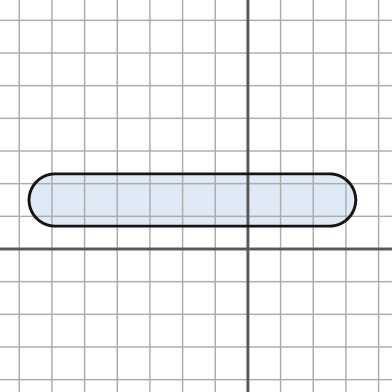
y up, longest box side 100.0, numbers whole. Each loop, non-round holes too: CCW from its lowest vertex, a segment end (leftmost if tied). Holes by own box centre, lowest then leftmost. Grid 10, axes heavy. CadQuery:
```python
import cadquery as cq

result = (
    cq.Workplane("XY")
    .moveTo(-59.0, 7.0)
    .lineTo(25.0, 7.0)
    .threePointArc((33.0, 15.0), (25.0, 23.0))
    .lineTo(-59.0, 23.0)
    .threePointArc((-67.0, 15.0), (-59.0, 7.0))
    .close()
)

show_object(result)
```